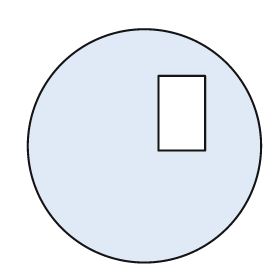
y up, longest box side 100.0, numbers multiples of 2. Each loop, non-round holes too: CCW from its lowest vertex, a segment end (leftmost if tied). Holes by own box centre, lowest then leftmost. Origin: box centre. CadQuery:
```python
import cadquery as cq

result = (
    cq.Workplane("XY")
    .moveTo(0.0, 0.0)
    .circle(50.0)
    .moveTo(6.0, -2.0)
    .lineTo(26.0, -2.0)
    .lineTo(26.0, 30.0)
    .lineTo(6.0, 30.0)
    .close()
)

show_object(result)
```